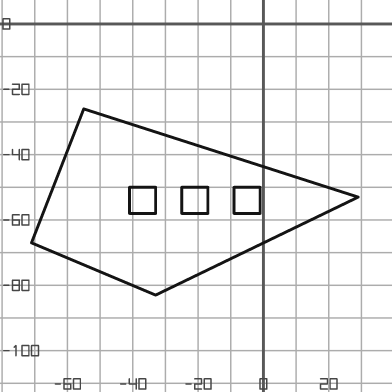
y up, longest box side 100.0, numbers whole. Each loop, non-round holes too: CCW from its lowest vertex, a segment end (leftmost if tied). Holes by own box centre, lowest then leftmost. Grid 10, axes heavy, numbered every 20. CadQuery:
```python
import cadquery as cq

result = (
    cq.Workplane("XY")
    .moveTo(-33.0, -83.0)
    .lineTo(29.0, -53.0)
    .lineTo(-55.0, -26.0)
    .lineTo(-71.0, -67.0)
    .close()
    .moveTo(-41.0, -58.0)
    .lineTo(-33.0, -58.0)
    .lineTo(-33.0, -50.0)
    .lineTo(-41.0, -50.0)
    .close()
    .moveTo(-25.0, -58.0)
    .lineTo(-17.0, -58.0)
    .lineTo(-17.0, -50.0)
    .lineTo(-25.0, -50.0)
    .close()
    .moveTo(-9.0, -58.0)
    .lineTo(-1.0, -58.0)
    .lineTo(-1.0, -50.0)
    .lineTo(-9.0, -50.0)
    .close()
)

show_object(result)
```